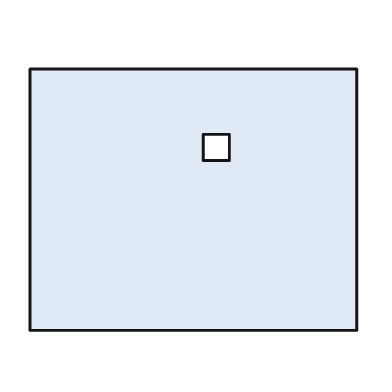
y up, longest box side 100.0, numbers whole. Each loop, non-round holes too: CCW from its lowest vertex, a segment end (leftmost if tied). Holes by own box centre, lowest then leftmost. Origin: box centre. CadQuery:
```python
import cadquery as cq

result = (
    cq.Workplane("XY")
    .moveTo(-50.0, -40.0)
    .lineTo(50.0, -40.0)
    .lineTo(50.0, 40.0)
    .lineTo(-50.0, 40.0)
    .close()
    .moveTo(3.0, 12.0)
    .lineTo(11.0, 12.0)
    .lineTo(11.0, 20.0)
    .lineTo(3.0, 20.0)
    .close()
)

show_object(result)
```